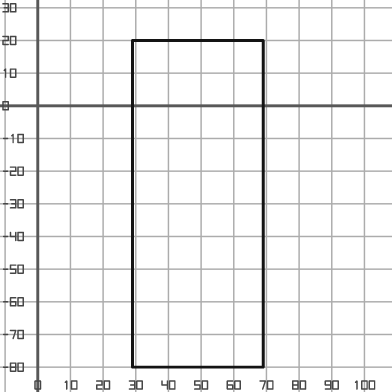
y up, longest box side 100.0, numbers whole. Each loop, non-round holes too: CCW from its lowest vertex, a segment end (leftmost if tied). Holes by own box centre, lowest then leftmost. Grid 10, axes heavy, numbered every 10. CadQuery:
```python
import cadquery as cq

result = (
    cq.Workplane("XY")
    .moveTo(29.0, -80.0)
    .lineTo(69.0, -80.0)
    .lineTo(69.0, 20.0)
    .lineTo(29.0, 20.0)
    .close()
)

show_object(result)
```